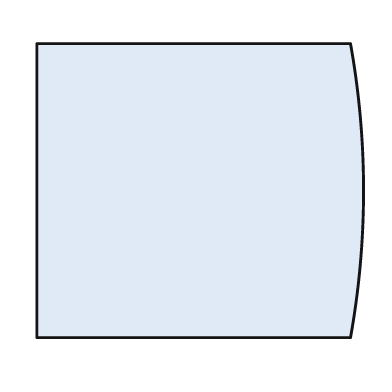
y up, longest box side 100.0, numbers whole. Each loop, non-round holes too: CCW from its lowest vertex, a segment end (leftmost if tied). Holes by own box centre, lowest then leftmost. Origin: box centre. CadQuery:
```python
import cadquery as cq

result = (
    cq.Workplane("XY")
    .moveTo(-50.0, -45.0)
    .lineTo(46.0, -45.0)
    .threePointArc((50.0, 0.0), (46.0, 45.0))
    .lineTo(-50.0, 45.0)
    .close()
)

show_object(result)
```